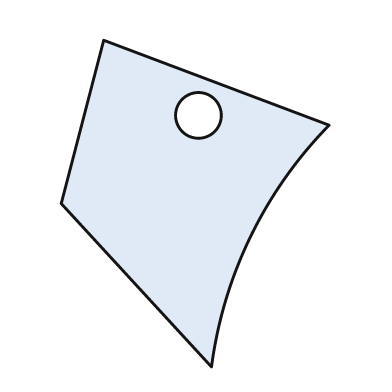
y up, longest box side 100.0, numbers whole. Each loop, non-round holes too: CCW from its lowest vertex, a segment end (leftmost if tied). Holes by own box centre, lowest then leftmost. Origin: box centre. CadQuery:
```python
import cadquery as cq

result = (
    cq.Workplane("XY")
    .moveTo(5.0, -50.0)
    .threePointArc((17.0, -10.0), (41.0, 24.0))
    .lineTo(-28.0, 50.0)
    .lineTo(-41.0, 0.0)
    .close()
    .moveTo(1.0, 27.0)
    .circle(7.0)
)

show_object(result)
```